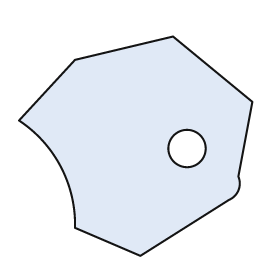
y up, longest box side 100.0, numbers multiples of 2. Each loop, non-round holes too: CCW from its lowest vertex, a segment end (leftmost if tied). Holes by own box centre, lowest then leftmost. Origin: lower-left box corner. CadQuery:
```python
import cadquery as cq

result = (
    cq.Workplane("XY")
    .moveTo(52.0, 0.0)
    .lineTo(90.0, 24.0)
    .threePointArc((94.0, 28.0), (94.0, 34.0))
    .lineTo(100.0, 66.0)
    .lineTo(66.0, 94.0)
    .lineTo(24.0, 84.0)
    .lineTo(0.0, 58.0)
    .threePointArc((18.0, 38.0), (24.0, 12.0))
    .close()
    .moveTo(72.0, 46.0)
    .circle(8.0)
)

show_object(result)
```